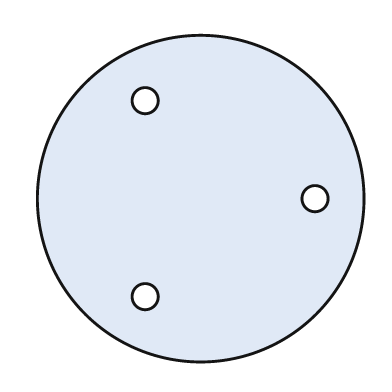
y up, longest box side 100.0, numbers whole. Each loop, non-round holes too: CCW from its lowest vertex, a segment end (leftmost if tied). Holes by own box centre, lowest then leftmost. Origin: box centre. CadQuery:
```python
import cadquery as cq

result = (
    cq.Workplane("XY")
    .moveTo(0.0, 0.0)
    .circle(50.0)
    .moveTo(-17.0, -30.0)
    .circle(4.0)
    .moveTo(35.0, 0.0)
    .circle(4.0)
    .moveTo(-17.0, 30.0)
    .circle(4.0)
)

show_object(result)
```